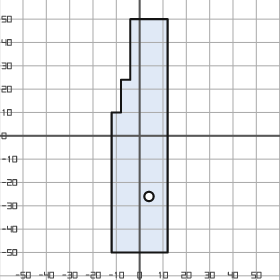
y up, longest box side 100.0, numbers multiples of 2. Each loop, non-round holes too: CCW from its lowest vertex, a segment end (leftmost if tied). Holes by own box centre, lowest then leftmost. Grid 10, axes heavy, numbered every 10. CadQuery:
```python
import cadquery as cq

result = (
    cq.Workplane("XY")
    .moveTo(-12.0, -50.0)
    .lineTo(12.0, -50.0)
    .lineTo(12.0, 50.0)
    .lineTo(-4.0, 50.0)
    .lineTo(-4.0, 24.0)
    .lineTo(-8.0, 24.0)
    .lineTo(-8.0, 10.0)
    .lineTo(-12.0, 10.0)
    .close()
    .moveTo(4.0, -26.0)
    .circle(2.0)
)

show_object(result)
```